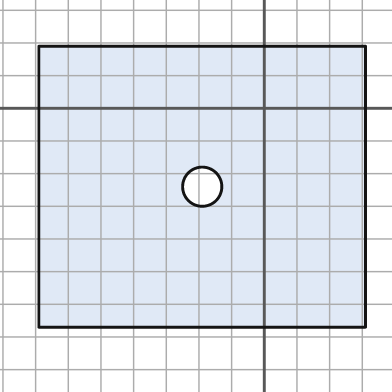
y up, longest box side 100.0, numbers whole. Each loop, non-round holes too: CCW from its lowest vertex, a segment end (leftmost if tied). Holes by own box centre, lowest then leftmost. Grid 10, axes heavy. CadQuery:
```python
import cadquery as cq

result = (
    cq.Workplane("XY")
    .moveTo(-69.0, -67.0)
    .lineTo(31.0, -67.0)
    .lineTo(31.0, 19.0)
    .lineTo(-69.0, 19.0)
    .close()
    .moveTo(-19.0, -24.0)
    .circle(6.0)
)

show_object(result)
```